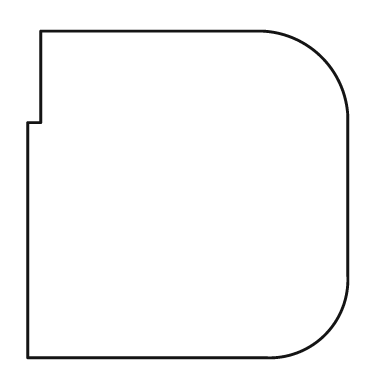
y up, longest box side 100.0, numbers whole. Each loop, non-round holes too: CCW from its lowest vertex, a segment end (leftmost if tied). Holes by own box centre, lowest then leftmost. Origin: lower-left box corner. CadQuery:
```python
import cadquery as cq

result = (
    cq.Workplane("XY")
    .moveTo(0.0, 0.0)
    .lineTo(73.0, 0.0)
    .threePointArc((91.0, 7.0), (98.0, 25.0))
    .lineTo(98.0, 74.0)
    .threePointArc((90.0, 92.0), (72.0, 100.0))
    .lineTo(4.0, 100.0)
    .lineTo(4.0, 72.0)
    .lineTo(0.0, 72.0)
    .close()
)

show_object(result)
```